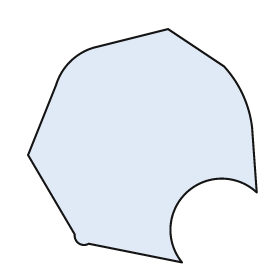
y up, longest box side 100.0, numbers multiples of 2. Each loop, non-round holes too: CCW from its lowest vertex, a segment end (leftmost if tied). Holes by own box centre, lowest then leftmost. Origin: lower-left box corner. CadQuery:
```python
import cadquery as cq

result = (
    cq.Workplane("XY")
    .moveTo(66.0, 0.0)
    .threePointArc((68.0, 30.0), (98.0, 30.0))
    .lineTo(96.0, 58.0)
    .threePointArc((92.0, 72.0), (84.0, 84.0))
    .lineTo(60.0, 100.0)
    .lineTo(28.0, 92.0)
    .threePointArc((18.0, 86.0), (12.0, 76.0))
    .lineTo(0.0, 46.0)
    .lineTo(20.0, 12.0)
    .threePointArc((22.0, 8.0), (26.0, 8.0))
    .close()
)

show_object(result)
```